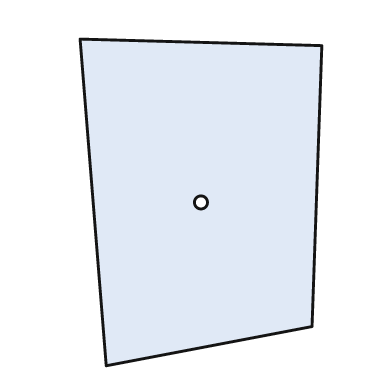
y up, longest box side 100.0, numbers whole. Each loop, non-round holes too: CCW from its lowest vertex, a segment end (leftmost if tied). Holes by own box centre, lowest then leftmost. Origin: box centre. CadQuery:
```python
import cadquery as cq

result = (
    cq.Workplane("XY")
    .moveTo(-29.0, -50.0)
    .lineTo(34.0, -38.0)
    .lineTo(37.0, 48.0)
    .lineTo(-37.0, 50.0)
    .close()
    .moveTo(0.0, 0.0)
    .circle(2.0)
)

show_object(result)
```